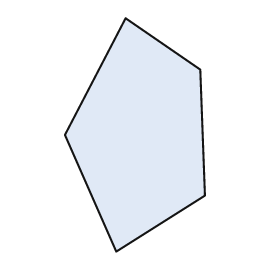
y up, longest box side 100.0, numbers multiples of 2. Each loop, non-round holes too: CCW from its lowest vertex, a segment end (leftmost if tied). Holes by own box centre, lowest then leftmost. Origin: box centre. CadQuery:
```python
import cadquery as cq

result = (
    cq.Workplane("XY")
    .moveTo(-8.0, -50.0)
    .lineTo(30.0, -26.0)
    .lineTo(28.0, 28.0)
    .lineTo(-4.0, 50.0)
    .lineTo(-30.0, 0.0)
    .close()
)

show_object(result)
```